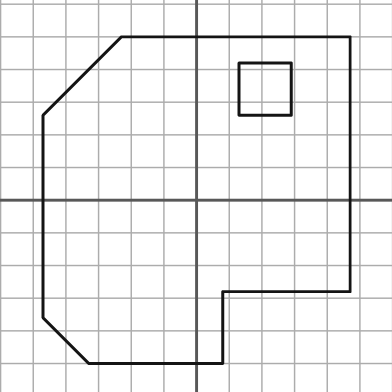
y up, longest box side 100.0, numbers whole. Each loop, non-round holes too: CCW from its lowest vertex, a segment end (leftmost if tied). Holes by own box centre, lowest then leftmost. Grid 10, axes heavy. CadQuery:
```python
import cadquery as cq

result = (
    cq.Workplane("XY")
    .moveTo(-33.0, -50.0)
    .lineTo(8.0, -50.0)
    .lineTo(8.0, -28.0)
    .lineTo(47.0, -28.0)
    .lineTo(47.0, 50.0)
    .lineTo(-23.0, 50.0)
    .lineTo(-47.0, 26.0)
    .lineTo(-47.0, -36.0)
    .close()
    .moveTo(13.0, 26.0)
    .lineTo(29.0, 26.0)
    .lineTo(29.0, 42.0)
    .lineTo(13.0, 42.0)
    .close()
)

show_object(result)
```